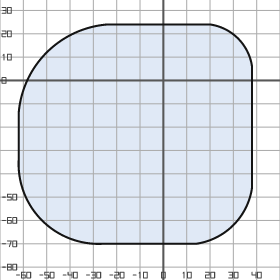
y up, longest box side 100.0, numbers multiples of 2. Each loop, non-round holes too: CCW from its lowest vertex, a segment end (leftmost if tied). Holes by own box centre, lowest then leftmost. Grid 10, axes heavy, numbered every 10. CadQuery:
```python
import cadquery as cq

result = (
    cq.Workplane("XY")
    .moveTo(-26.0, -70.0)
    .lineTo(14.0, -70.0)
    .threePointArc((30.0, -62.0), (38.0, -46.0))
    .lineTo(38.0, 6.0)
    .threePointArc((32.0, 18.0), (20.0, 24.0))
    .lineTo(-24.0, 24.0)
    .threePointArc((-50.0, 12.0), (-62.0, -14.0))
    .lineTo(-62.0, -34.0)
    .threePointArc((-52.0, -60.0), (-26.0, -70.0))
    .close()
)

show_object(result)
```